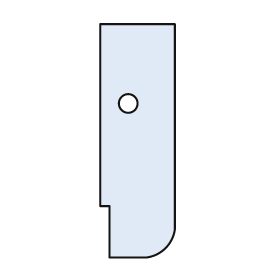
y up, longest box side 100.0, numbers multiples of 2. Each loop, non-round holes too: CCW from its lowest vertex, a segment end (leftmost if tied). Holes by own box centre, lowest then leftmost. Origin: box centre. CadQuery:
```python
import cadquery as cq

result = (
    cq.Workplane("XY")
    .moveTo(-12.0, -50.0)
    .lineTo(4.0, -50.0)
    .threePointArc((12.0, -46.0), (16.0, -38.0))
    .lineTo(16.0, 50.0)
    .lineTo(-16.0, 50.0)
    .lineTo(-16.0, -28.0)
    .lineTo(-12.0, -28.0)
    .close()
    .moveTo(-4.0, 16.0)
    .circle(4.0)
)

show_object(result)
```